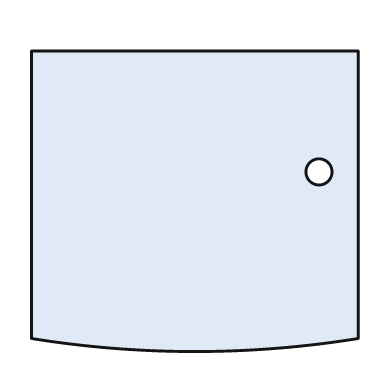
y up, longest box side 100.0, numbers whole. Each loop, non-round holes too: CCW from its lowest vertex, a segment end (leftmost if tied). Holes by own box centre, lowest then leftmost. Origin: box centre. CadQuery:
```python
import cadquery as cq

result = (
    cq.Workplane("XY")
    .moveTo(-50.0, -42.0)
    .threePointArc((0.0, -46.0), (50.0, -42.0))
    .lineTo(50.0, 46.0)
    .lineTo(-50.0, 46.0)
    .close()
    .moveTo(38.0, 9.0)
    .circle(4.0)
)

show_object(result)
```